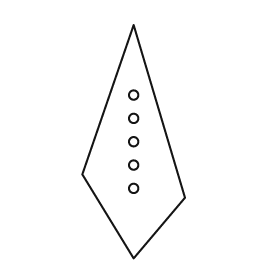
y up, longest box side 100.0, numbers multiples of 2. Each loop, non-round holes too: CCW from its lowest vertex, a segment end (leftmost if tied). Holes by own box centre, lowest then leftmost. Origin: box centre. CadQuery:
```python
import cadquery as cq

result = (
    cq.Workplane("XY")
    .moveTo(0.0, -50.0)
    .lineTo(22.0, -24.0)
    .lineTo(0.0, 50.0)
    .lineTo(-22.0, -14.0)
    .close()
    .moveTo(0.0, -20.0)
    .circle(2.0)
    .moveTo(0.0, -10.0)
    .circle(2.0)
    .moveTo(0.0, 0.0)
    .circle(2.0)
    .moveTo(0.0, 10.0)
    .circle(2.0)
    .moveTo(0.0, 20.0)
    .circle(2.0)
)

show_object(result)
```